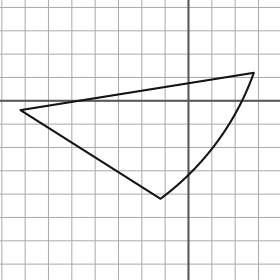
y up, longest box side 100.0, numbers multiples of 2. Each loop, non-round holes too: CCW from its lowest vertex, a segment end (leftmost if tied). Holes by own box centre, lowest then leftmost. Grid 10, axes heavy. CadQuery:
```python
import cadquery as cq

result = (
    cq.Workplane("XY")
    .moveTo(-12.0, -42.0)
    .threePointArc((12.0, -18.0), (28.0, 12.0))
    .lineTo(-72.0, -4.0)
    .close()
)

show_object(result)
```